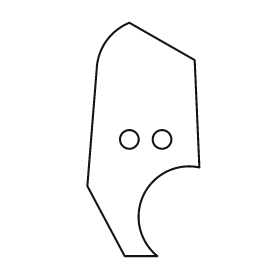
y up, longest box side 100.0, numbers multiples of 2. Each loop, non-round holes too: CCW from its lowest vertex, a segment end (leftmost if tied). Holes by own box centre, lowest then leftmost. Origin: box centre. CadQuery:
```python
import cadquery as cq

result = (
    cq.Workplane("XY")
    .moveTo(-8.0, -50.0)
    .lineTo(6.0, -50.0)
    .threePointArc((0.0, -24.0), (24.0, -12.0))
    .lineTo(22.0, 34.0)
    .lineTo(-6.0, 50.0)
    .threePointArc((-16.0, 42.0), (-20.0, 30.0))
    .lineTo(-24.0, -20.0)
    .close()
    .moveTo(-6.0, 0.0)
    .circle(4.0)
    .moveTo(8.0, 0.0)
    .circle(4.0)
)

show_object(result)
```